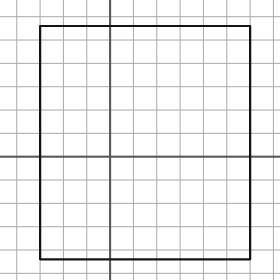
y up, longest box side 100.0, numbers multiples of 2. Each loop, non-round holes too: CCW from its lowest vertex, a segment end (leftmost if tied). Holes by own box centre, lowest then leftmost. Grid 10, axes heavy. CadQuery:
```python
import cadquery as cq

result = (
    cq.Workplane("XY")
    .moveTo(-30.0, -44.0)
    .lineTo(60.0, -44.0)
    .lineTo(60.0, 56.0)
    .lineTo(-30.0, 56.0)
    .close()
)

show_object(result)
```